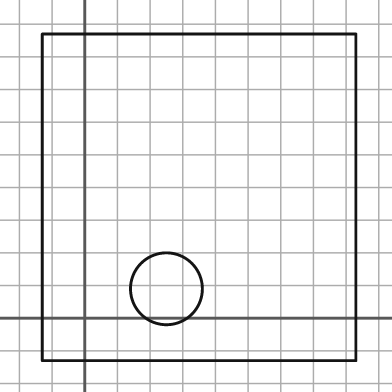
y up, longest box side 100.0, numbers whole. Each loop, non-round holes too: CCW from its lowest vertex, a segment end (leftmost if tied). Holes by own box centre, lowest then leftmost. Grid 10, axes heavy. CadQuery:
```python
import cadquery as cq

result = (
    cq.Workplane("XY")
    .moveTo(-13.0, -13.0)
    .lineTo(83.0, -13.0)
    .lineTo(83.0, 87.0)
    .lineTo(-13.0, 87.0)
    .close()
    .moveTo(25.0, 9.0)
    .circle(11.0)
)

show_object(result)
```